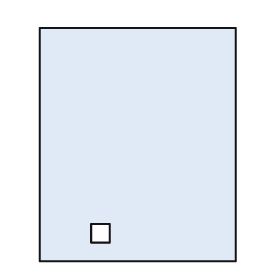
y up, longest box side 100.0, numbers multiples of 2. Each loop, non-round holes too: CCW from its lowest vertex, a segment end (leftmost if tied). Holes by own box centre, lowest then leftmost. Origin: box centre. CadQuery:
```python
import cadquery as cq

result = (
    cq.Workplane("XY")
    .moveTo(-42.0, -50.0)
    .lineTo(42.0, -50.0)
    .lineTo(42.0, 50.0)
    .lineTo(-42.0, 50.0)
    .close()
    .moveTo(-20.0, -42.0)
    .lineTo(-12.0, -42.0)
    .lineTo(-12.0, -34.0)
    .lineTo(-20.0, -34.0)
    .close()
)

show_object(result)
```